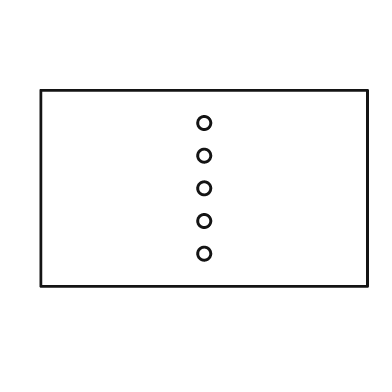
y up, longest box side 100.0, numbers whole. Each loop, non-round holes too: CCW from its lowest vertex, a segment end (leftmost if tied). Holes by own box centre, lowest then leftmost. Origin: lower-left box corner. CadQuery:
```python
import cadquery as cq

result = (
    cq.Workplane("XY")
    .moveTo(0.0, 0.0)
    .lineTo(100.0, 0.0)
    .lineTo(100.0, 60.0)
    .lineTo(0.0, 60.0)
    .close()
    .moveTo(50.0, 10.0)
    .circle(2.0)
    .moveTo(50.0, 20.0)
    .circle(2.0)
    .moveTo(50.0, 30.0)
    .circle(2.0)
    .moveTo(50.0, 40.0)
    .circle(2.0)
    .moveTo(50.0, 50.0)
    .circle(2.0)
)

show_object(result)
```